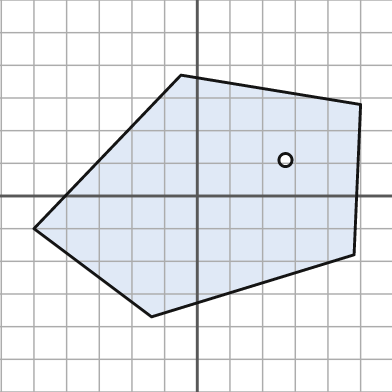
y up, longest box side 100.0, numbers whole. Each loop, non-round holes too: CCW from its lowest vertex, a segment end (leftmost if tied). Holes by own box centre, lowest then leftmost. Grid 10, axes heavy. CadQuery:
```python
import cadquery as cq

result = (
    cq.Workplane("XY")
    .moveTo(-14.0, -37.0)
    .lineTo(48.0, -18.0)
    .lineTo(50.0, 28.0)
    .lineTo(-5.0, 37.0)
    .lineTo(-50.0, -10.0)
    .close()
    .moveTo(27.0, 11.0)
    .circle(2.0)
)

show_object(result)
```